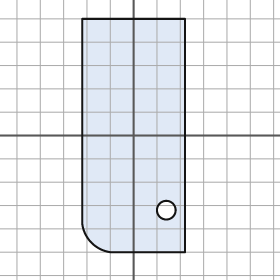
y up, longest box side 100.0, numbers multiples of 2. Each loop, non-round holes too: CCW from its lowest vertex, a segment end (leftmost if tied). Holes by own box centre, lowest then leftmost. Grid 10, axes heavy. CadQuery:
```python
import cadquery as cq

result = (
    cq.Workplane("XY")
    .moveTo(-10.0, -50.0)
    .lineTo(22.0, -50.0)
    .lineTo(22.0, 50.0)
    .lineTo(-22.0, 50.0)
    .lineTo(-22.0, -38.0)
    .threePointArc((-18.0, -46.0), (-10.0, -50.0))
    .close()
    .moveTo(14.0, -32.0)
    .circle(4.0)
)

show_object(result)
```